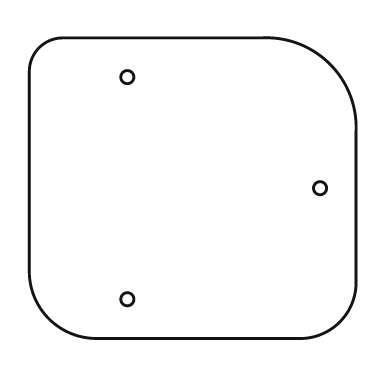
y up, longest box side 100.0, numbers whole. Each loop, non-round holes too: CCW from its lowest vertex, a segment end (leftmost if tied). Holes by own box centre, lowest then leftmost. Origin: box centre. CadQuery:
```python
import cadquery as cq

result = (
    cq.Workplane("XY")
    .moveTo(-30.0, -46.0)
    .lineTo(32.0, -46.0)
    .threePointArc((45.0, -41.0), (50.0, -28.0))
    .lineTo(50.0, 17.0)
    .threePointArc((42.0, 38.0), (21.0, 46.0))
    .lineTo(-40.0, 46.0)
    .threePointArc((-47.0, 43.0), (-50.0, 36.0))
    .lineTo(-50.0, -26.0)
    .threePointArc((-44.0, -40.0), (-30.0, -46.0))
    .close()
    .moveTo(-20.0, -34.0)
    .circle(2.0)
    .moveTo(39.0, 0.0)
    .circle(2.0)
    .moveTo(-20.0, 34.0)
    .circle(2.0)
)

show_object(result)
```